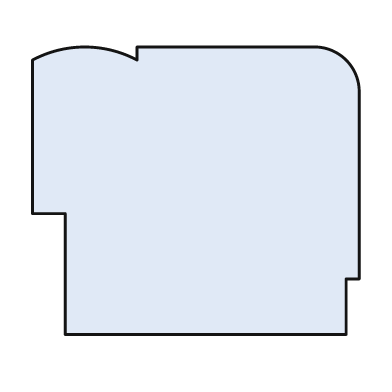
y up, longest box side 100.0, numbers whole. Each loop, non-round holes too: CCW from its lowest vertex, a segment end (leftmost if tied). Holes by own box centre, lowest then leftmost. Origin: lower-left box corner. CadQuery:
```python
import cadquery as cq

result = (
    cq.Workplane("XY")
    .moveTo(10.0, 0.0)
    .lineTo(96.0, 0.0)
    .lineTo(96.0, 17.0)
    .lineTo(100.0, 17.0)
    .lineTo(100.0, 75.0)
    .threePointArc((96.0, 84.0), (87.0, 88.0))
    .lineTo(32.0, 88.0)
    .lineTo(32.0, 84.0)
    .threePointArc((16.0, 88.0), (0.0, 84.0))
    .lineTo(0.0, 37.0)
    .lineTo(10.0, 37.0)
    .close()
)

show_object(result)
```